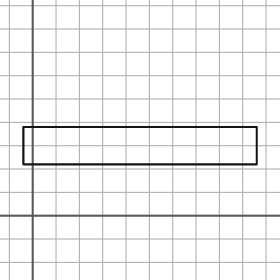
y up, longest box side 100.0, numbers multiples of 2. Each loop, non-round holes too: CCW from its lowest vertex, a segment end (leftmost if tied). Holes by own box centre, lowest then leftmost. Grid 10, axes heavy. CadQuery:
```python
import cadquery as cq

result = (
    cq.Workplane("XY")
    .moveTo(-4.0, 22.0)
    .lineTo(96.0, 22.0)
    .lineTo(96.0, 38.0)
    .lineTo(-4.0, 38.0)
    .close()
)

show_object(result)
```